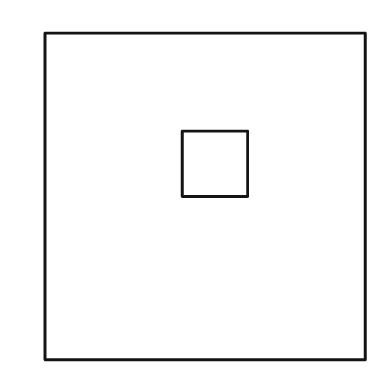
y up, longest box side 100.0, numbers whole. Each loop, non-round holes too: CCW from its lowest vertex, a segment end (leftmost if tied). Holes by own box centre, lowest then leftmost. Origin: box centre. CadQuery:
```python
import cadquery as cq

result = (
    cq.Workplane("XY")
    .moveTo(-49.0, -50.0)
    .lineTo(49.0, -50.0)
    .lineTo(49.0, 50.0)
    .lineTo(-49.0, 50.0)
    .close()
    .moveTo(-7.0, 0.0)
    .lineTo(13.0, 0.0)
    .lineTo(13.0, 20.0)
    .lineTo(-7.0, 20.0)
    .close()
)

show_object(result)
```